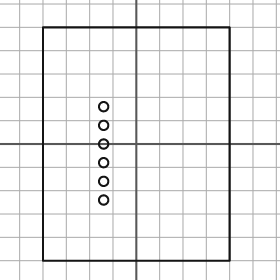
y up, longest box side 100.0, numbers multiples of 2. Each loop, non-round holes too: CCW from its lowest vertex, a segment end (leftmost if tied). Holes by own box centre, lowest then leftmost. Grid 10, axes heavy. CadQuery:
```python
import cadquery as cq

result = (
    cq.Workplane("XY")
    .moveTo(-40.0, -50.0)
    .lineTo(40.0, -50.0)
    .lineTo(40.0, 50.0)
    .lineTo(-40.0, 50.0)
    .close()
    .moveTo(-14.0, -24.0)
    .circle(2.0)
    .moveTo(-14.0, -16.0)
    .circle(2.0)
    .moveTo(-14.0, -8.0)
    .circle(2.0)
    .moveTo(-14.0, 0.0)
    .circle(2.0)
    .moveTo(-14.0, 8.0)
    .circle(2.0)
    .moveTo(-14.0, 16.0)
    .circle(2.0)
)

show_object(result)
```